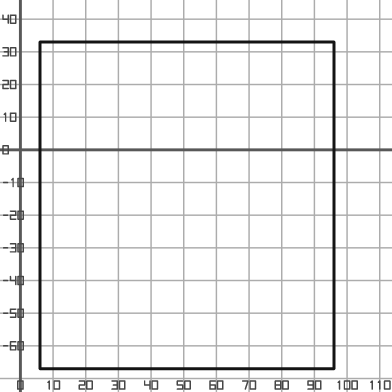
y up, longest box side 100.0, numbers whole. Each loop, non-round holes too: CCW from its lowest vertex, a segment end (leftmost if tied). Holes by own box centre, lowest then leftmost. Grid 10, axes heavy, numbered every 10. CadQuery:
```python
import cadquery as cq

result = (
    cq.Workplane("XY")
    .moveTo(6.0, -67.0)
    .lineTo(96.0, -67.0)
    .lineTo(96.0, 33.0)
    .lineTo(6.0, 33.0)
    .close()
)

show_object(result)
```